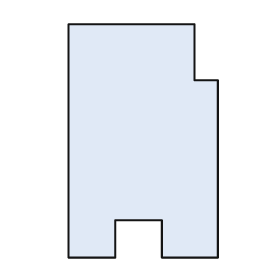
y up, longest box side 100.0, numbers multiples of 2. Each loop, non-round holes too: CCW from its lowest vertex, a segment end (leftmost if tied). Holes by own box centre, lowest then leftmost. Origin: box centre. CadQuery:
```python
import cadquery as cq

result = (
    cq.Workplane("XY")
    .moveTo(-32.0, -50.0)
    .lineTo(-12.0, -50.0)
    .lineTo(-12.0, -34.0)
    .lineTo(8.0, -34.0)
    .lineTo(8.0, -50.0)
    .lineTo(32.0, -50.0)
    .lineTo(32.0, 26.0)
    .lineTo(22.0, 26.0)
    .lineTo(22.0, 50.0)
    .lineTo(-32.0, 50.0)
    .close()
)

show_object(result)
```